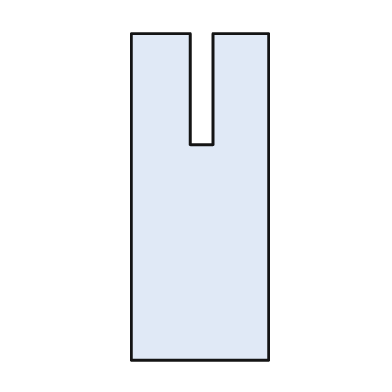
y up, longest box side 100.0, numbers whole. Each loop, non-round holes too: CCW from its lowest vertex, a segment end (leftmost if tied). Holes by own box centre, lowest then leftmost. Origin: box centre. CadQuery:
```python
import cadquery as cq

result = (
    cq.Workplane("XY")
    .moveTo(-21.0, -50.0)
    .lineTo(21.0, -50.0)
    .lineTo(21.0, 50.0)
    .lineTo(4.0, 50.0)
    .lineTo(4.0, 16.0)
    .lineTo(-3.0, 16.0)
    .lineTo(-3.0, 50.0)
    .lineTo(-21.0, 50.0)
    .close()
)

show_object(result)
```